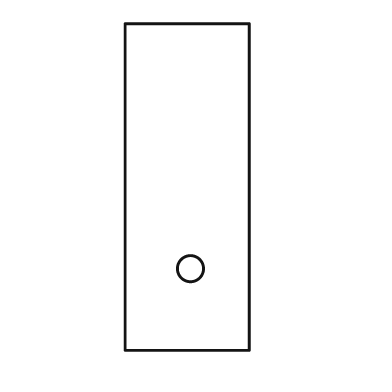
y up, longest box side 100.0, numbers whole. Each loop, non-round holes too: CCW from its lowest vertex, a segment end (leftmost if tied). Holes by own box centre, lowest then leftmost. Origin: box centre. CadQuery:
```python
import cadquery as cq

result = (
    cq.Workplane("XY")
    .moveTo(-19.0, -50.0)
    .lineTo(19.0, -50.0)
    .lineTo(19.0, 50.0)
    .lineTo(-19.0, 50.0)
    .close()
    .moveTo(1.0, -25.0)
    .circle(4.0)
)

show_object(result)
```